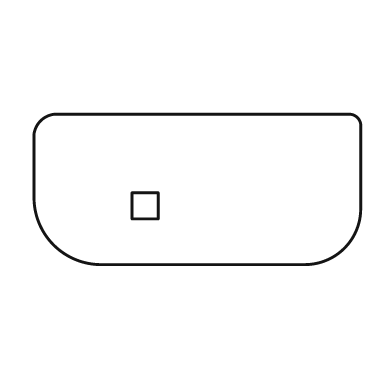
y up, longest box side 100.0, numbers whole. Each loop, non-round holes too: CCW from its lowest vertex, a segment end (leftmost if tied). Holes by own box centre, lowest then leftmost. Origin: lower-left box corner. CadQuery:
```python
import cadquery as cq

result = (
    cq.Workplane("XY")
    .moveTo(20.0, 0.0)
    .lineTo(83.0, 0.0)
    .threePointArc((95.0, 5.0), (100.0, 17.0))
    .lineTo(100.0, 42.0)
    .threePointArc((99.0, 45.0), (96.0, 46.0))
    .lineTo(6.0, 46.0)
    .threePointArc((2.0, 44.0), (0.0, 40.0))
    .lineTo(0.0, 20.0)
    .threePointArc((6.0, 6.0), (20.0, 0.0))
    .close()
    .moveTo(30.0, 14.0)
    .lineTo(38.0, 14.0)
    .lineTo(38.0, 22.0)
    .lineTo(30.0, 22.0)
    .close()
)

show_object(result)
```